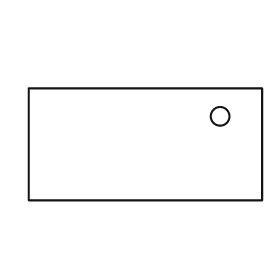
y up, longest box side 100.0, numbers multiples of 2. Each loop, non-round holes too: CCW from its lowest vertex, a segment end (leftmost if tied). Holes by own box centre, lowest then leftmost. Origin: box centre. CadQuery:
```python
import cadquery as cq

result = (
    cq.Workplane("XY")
    .moveTo(-50.0, -24.0)
    .lineTo(50.0, -24.0)
    .lineTo(50.0, 24.0)
    .lineTo(-50.0, 24.0)
    .close()
    .moveTo(32.0, 12.0)
    .circle(4.0)
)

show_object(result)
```